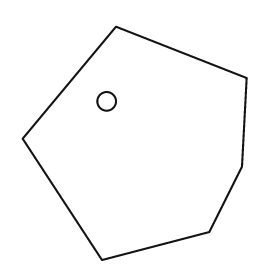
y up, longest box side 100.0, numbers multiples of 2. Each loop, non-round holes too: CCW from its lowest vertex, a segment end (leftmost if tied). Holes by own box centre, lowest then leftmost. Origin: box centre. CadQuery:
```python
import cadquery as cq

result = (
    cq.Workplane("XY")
    .moveTo(-14.0, -50.0)
    .lineTo(32.0, -38.0)
    .lineTo(46.0, -10.0)
    .lineTo(48.0, 28.0)
    .lineTo(-8.0, 50.0)
    .lineTo(-48.0, 2.0)
    .close()
    .moveTo(-12.0, 18.0)
    .circle(4.0)
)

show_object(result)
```